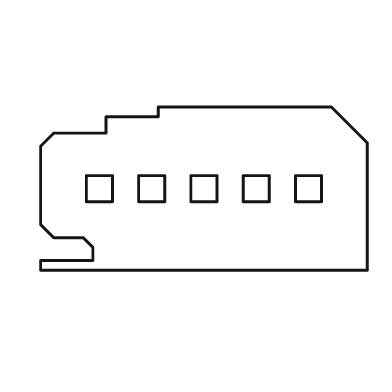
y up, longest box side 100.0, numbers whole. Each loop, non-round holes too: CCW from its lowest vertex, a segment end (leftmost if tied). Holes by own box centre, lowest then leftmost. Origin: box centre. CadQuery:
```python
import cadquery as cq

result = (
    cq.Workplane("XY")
    .moveTo(-50.0, -25.0)
    .lineTo(50.0, -25.0)
    .lineTo(50.0, 14.0)
    .lineTo(39.0, 25.0)
    .lineTo(-14.0, 25.0)
    .lineTo(-14.0, 22.0)
    .lineTo(-30.0, 22.0)
    .lineTo(-30.0, 17.0)
    .lineTo(-46.0, 17.0)
    .lineTo(-50.0, 13.0)
    .lineTo(-50.0, -11.0)
    .lineTo(-46.0, -15.0)
    .lineTo(-37.0, -15.0)
    .lineTo(-34.0, -18.0)
    .lineTo(-34.0, -22.0)
    .lineTo(-50.0, -22.0)
    .close()
    .moveTo(-36.0, -4.0)
    .lineTo(-28.0, -4.0)
    .lineTo(-28.0, 4.0)
    .lineTo(-36.0, 4.0)
    .close()
    .moveTo(-20.0, -4.0)
    .lineTo(-12.0, -4.0)
    .lineTo(-12.0, 4.0)
    .lineTo(-20.0, 4.0)
    .close()
    .moveTo(-4.0, -4.0)
    .lineTo(4.0, -4.0)
    .lineTo(4.0, 4.0)
    .lineTo(-4.0, 4.0)
    .close()
    .moveTo(12.0, -4.0)
    .lineTo(20.0, -4.0)
    .lineTo(20.0, 4.0)
    .lineTo(12.0, 4.0)
    .close()
    .moveTo(28.0, -4.0)
    .lineTo(36.0, -4.0)
    .lineTo(36.0, 4.0)
    .lineTo(28.0, 4.0)
    .close()
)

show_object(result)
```